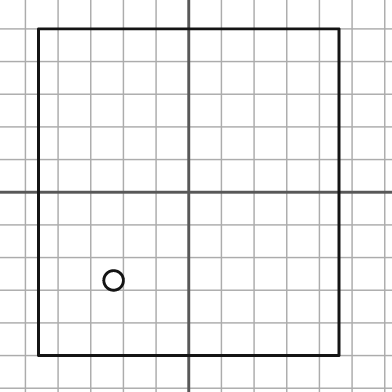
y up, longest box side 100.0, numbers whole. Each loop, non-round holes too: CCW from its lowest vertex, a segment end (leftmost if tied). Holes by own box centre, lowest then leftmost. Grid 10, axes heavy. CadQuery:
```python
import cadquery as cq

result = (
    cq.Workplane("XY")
    .moveTo(-46.0, -50.0)
    .lineTo(46.0, -50.0)
    .lineTo(46.0, 50.0)
    .lineTo(-46.0, 50.0)
    .close()
    .moveTo(-23.0, -27.0)
    .circle(3.0)
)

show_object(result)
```